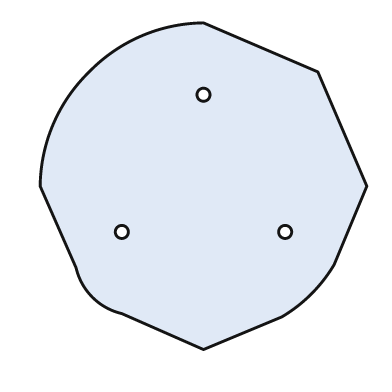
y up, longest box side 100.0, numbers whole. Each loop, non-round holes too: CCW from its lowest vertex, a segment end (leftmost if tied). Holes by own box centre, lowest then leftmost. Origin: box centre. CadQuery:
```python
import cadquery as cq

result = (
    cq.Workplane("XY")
    .moveTo(0.0, -50.0)
    .lineTo(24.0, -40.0)
    .threePointArc((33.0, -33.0), (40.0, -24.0))
    .lineTo(50.0, 0.0)
    .lineTo(35.0, 35.0)
    .lineTo(0.0, 50.0)
    .threePointArc((-19.0, 46.0), (-35.0, 35.0))
    .threePointArc((-46.0, 19.0), (-50.0, 0.0))
    .lineTo(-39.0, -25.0)
    .threePointArc((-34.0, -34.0), (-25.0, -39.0))
    .close()
    .moveTo(-25.0, -14.0)
    .circle(2.0)
    .moveTo(25.0, -14.0)
    .circle(2.0)
    .moveTo(0.0, 28.0)
    .circle(2.0)
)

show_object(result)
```